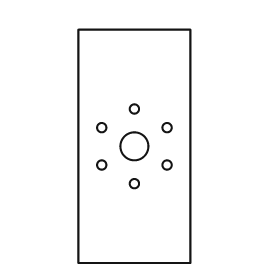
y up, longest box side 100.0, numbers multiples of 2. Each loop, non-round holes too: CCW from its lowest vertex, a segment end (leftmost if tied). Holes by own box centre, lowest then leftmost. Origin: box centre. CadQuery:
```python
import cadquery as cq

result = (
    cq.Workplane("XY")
    .moveTo(-24.0, -50.0)
    .lineTo(24.0, -50.0)
    .lineTo(24.0, 50.0)
    .lineTo(-24.0, 50.0)
    .close()
    .moveTo(0.0, -16.0)
    .circle(2.0)
    .moveTo(-14.0, -8.0)
    .circle(2.0)
    .moveTo(14.0, -8.0)
    .circle(2.0)
    .moveTo(0.0, 0.0)
    .circle(6.0)
    .moveTo(-14.0, 8.0)
    .circle(2.0)
    .moveTo(14.0, 8.0)
    .circle(2.0)
    .moveTo(0.0, 16.0)
    .circle(2.0)
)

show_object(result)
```